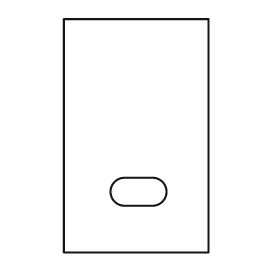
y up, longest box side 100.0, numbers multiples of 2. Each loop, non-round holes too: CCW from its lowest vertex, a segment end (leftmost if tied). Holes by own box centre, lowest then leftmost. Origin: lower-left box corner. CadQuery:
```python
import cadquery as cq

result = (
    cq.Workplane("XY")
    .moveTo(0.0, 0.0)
    .lineTo(62.0, 0.0)
    .lineTo(62.0, 100.0)
    .lineTo(0.0, 100.0)
    .close()
    .moveTo(26.0, 20.0)
    .lineTo(38.0, 20.0)
    .threePointArc((44.0, 26.0), (38.0, 32.0))
    .lineTo(26.0, 32.0)
    .threePointArc((20.0, 26.0), (26.0, 20.0))
    .close()
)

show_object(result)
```